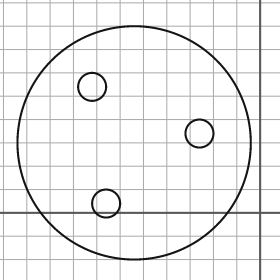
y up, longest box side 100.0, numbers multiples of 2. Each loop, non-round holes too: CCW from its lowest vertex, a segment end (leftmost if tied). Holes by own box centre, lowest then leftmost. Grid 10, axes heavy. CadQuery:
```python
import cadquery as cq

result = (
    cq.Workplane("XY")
    .moveTo(-54.0, 30.0)
    .circle(50.0)
    .moveTo(-66.0, 4.0)
    .circle(6.0)
    .moveTo(-26.0, 34.0)
    .circle(6.0)
    .moveTo(-72.0, 54.0)
    .circle(6.0)
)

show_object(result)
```